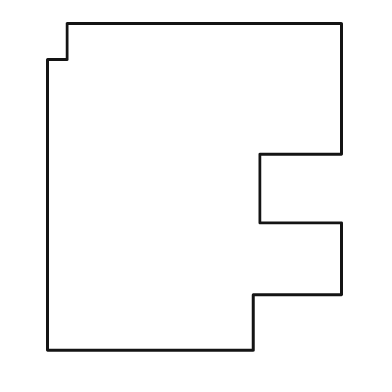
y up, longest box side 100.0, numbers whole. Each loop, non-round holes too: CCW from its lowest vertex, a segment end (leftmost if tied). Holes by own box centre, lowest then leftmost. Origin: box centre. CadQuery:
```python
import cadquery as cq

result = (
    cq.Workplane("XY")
    .moveTo(-45.0, -50.0)
    .lineTo(18.0, -50.0)
    .lineTo(18.0, -33.0)
    .lineTo(45.0, -33.0)
    .lineTo(45.0, -11.0)
    .lineTo(20.0, -11.0)
    .lineTo(20.0, 10.0)
    .lineTo(45.0, 10.0)
    .lineTo(45.0, 50.0)
    .lineTo(-39.0, 50.0)
    .lineTo(-39.0, 39.0)
    .lineTo(-45.0, 39.0)
    .close()
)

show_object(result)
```